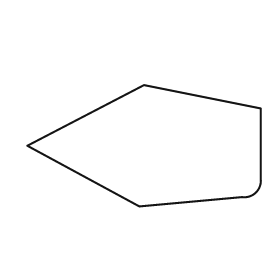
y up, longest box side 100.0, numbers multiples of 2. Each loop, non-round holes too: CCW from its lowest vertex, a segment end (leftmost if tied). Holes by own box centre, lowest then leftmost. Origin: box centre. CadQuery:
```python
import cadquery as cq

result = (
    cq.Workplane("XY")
    .moveTo(-2.0, -26.0)
    .lineTo(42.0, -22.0)
    .threePointArc((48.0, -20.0), (50.0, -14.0))
    .lineTo(50.0, 16.0)
    .lineTo(0.0, 26.0)
    .lineTo(-50.0, 0.0)
    .close()
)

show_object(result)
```